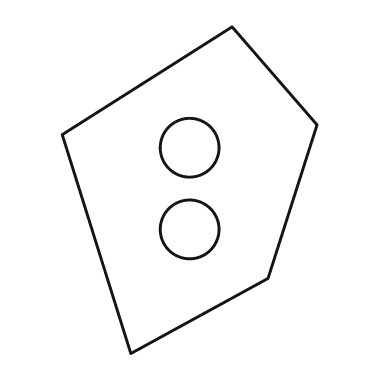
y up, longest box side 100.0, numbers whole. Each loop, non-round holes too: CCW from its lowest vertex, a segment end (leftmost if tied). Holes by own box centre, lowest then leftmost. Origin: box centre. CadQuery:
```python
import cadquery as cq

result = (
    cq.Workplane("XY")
    .moveTo(-18.0, -50.0)
    .lineTo(24.0, -27.0)
    .lineTo(39.0, 20.0)
    .lineTo(13.0, 50.0)
    .lineTo(-39.0, 17.0)
    .close()
    .moveTo(0.0, -12.0)
    .circle(9.0)
    .moveTo(0.0, 13.0)
    .circle(9.0)
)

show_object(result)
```